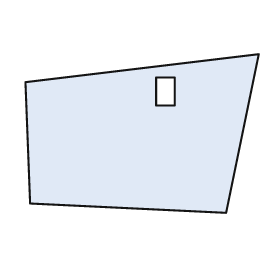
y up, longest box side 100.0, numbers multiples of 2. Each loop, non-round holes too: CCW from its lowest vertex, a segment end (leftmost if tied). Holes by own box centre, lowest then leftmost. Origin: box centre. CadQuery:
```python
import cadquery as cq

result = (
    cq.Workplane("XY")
    .moveTo(36.0, -34.0)
    .lineTo(50.0, 34.0)
    .lineTo(-50.0, 22.0)
    .lineTo(-48.0, -30.0)
    .close()
    .moveTo(6.0, 12.0)
    .lineTo(14.0, 12.0)
    .lineTo(14.0, 24.0)
    .lineTo(6.0, 24.0)
    .close()
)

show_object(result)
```